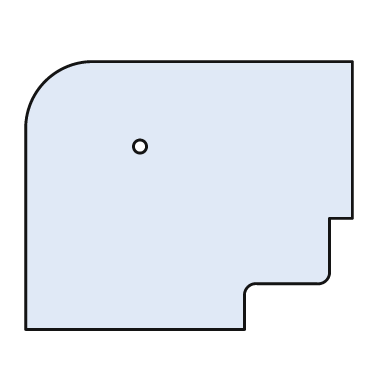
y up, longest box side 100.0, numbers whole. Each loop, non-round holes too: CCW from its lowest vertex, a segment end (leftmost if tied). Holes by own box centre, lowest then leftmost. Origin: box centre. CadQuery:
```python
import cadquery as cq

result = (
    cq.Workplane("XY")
    .moveTo(-50.0, -41.0)
    .lineTo(17.0, -41.0)
    .lineTo(17.0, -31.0)
    .threePointArc((18.0, -28.0), (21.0, -27.0))
    .lineTo(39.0, -27.0)
    .threePointArc((42.0, -26.0), (43.0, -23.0))
    .lineTo(43.0, -7.0)
    .lineTo(50.0, -7.0)
    .lineTo(50.0, 41.0)
    .lineTo(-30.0, 41.0)
    .threePointArc((-44.0, 35.0), (-50.0, 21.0))
    .close()
    .moveTo(-15.0, 15.0)
    .circle(2.0)
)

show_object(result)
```